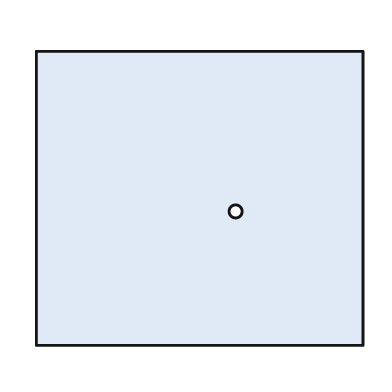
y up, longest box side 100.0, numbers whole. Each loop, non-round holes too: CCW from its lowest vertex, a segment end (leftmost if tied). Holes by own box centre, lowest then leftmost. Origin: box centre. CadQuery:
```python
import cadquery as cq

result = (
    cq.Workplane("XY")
    .moveTo(-50.0, -45.0)
    .lineTo(50.0, -45.0)
    .lineTo(50.0, 45.0)
    .lineTo(-50.0, 45.0)
    .close()
    .moveTo(11.0, -4.0)
    .circle(2.0)
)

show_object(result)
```